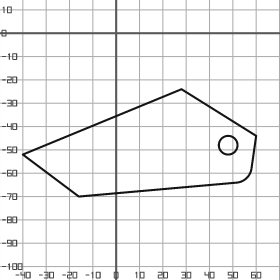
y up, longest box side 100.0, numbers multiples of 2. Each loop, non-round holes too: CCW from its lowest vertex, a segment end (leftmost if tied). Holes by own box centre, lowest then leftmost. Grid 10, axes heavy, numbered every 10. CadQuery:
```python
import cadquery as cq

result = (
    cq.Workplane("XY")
    .moveTo(-16.0, -70.0)
    .lineTo(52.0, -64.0)
    .threePointArc((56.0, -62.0), (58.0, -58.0))
    .lineTo(60.0, -44.0)
    .lineTo(28.0, -24.0)
    .lineTo(-40.0, -52.0)
    .close()
    .moveTo(48.0, -48.0)
    .circle(4.0)
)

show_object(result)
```